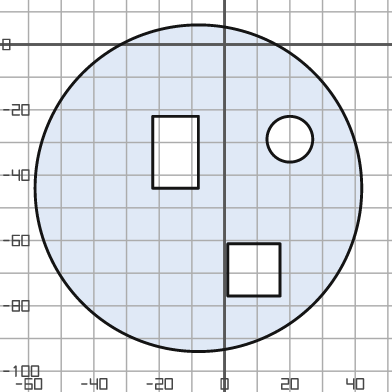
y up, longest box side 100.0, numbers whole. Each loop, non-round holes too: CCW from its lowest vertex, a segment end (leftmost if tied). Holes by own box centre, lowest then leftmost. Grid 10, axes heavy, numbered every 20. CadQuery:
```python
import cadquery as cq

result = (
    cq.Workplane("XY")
    .moveTo(-8.0, -44.0)
    .circle(50.0)
    .moveTo(1.0, -77.0)
    .lineTo(17.0, -77.0)
    .lineTo(17.0, -61.0)
    .lineTo(1.0, -61.0)
    .close()
    .moveTo(-22.0, -44.0)
    .lineTo(-8.0, -44.0)
    .lineTo(-8.0, -22.0)
    .lineTo(-22.0, -22.0)
    .close()
    .moveTo(20.0, -29.0)
    .circle(7.0)
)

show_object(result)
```